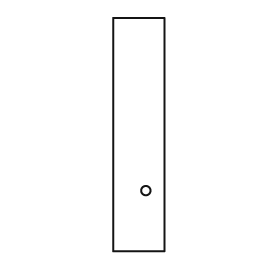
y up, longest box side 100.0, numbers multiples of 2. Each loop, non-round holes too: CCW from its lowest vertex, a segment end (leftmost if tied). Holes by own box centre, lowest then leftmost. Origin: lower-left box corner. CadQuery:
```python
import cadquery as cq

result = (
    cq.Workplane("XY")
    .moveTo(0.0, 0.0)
    .lineTo(22.0, 0.0)
    .lineTo(22.0, 100.0)
    .lineTo(0.0, 100.0)
    .close()
    .moveTo(14.0, 26.0)
    .circle(2.0)
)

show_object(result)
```